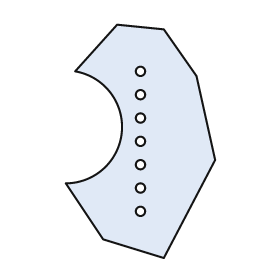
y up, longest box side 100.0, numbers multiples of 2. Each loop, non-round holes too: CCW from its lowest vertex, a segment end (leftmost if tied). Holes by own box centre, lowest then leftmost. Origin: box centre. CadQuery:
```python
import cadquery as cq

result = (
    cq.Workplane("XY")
    .moveTo(10.0, -50.0)
    .lineTo(32.0, -8.0)
    .lineTo(24.0, 28.0)
    .lineTo(10.0, 48.0)
    .lineTo(-10.0, 50.0)
    .lineTo(-28.0, 30.0)
    .threePointArc((-8.0, 4.0), (-32.0, -18.0))
    .lineTo(-16.0, -42.0)
    .close()
    .moveTo(0.0, -30.0)
    .circle(2.0)
    .moveTo(0.0, -20.0)
    .circle(2.0)
    .moveTo(0.0, -10.0)
    .circle(2.0)
    .moveTo(0.0, 0.0)
    .circle(2.0)
    .moveTo(0.0, 10.0)
    .circle(2.0)
    .moveTo(0.0, 20.0)
    .circle(2.0)
    .moveTo(0.0, 30.0)
    .circle(2.0)
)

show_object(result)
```